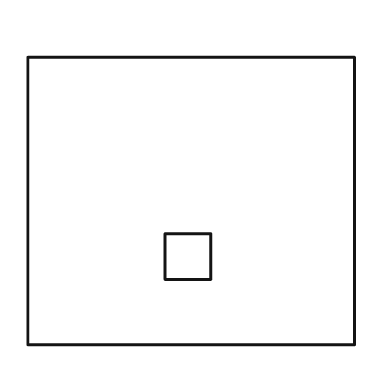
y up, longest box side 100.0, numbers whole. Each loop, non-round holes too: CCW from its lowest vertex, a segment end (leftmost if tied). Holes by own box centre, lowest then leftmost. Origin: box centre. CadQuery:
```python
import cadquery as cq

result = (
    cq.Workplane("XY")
    .moveTo(-50.0, -44.0)
    .lineTo(50.0, -44.0)
    .lineTo(50.0, 44.0)
    .lineTo(-50.0, 44.0)
    .close()
    .moveTo(-8.0, -24.0)
    .lineTo(6.0, -24.0)
    .lineTo(6.0, -10.0)
    .lineTo(-8.0, -10.0)
    .close()
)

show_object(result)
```